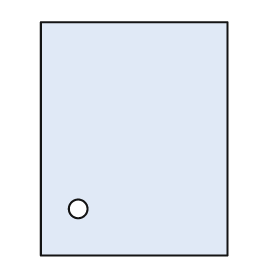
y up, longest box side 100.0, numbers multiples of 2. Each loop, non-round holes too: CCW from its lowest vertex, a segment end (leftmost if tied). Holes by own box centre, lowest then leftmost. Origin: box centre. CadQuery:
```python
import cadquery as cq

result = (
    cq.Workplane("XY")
    .moveTo(-40.0, -50.0)
    .lineTo(40.0, -50.0)
    .lineTo(40.0, 50.0)
    .lineTo(-40.0, 50.0)
    .close()
    .moveTo(-24.0, -30.0)
    .circle(4.0)
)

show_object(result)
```